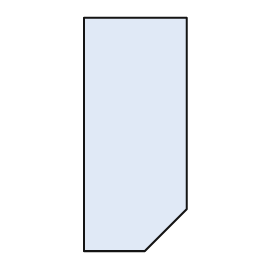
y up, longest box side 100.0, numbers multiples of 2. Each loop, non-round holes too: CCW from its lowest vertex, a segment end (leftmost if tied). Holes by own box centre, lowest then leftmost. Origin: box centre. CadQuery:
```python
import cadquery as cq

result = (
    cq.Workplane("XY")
    .moveTo(-22.0, -50.0)
    .lineTo(4.0, -50.0)
    .lineTo(22.0, -32.0)
    .lineTo(22.0, 50.0)
    .lineTo(-22.0, 50.0)
    .close()
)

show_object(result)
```